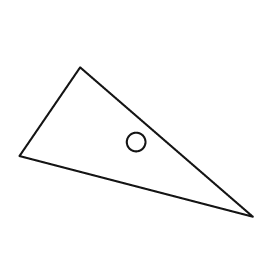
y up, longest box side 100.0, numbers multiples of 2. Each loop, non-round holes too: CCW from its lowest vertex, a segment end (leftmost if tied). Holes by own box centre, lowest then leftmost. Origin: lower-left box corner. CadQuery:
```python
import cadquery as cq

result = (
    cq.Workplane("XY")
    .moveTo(100.0, 0.0)
    .lineTo(26.0, 64.0)
    .lineTo(0.0, 26.0)
    .close()
    .moveTo(50.0, 32.0)
    .circle(4.0)
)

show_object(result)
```